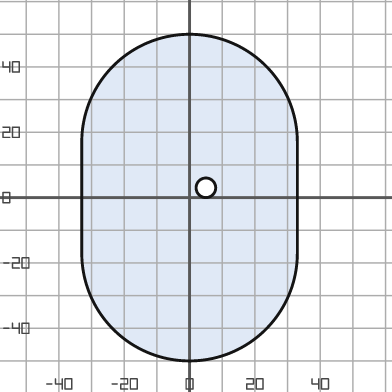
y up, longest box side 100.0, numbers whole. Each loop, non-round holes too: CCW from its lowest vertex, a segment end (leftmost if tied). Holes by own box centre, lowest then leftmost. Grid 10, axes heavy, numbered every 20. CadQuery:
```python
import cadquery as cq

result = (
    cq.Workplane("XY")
    .moveTo(-33.0, -17.0)
    .threePointArc((0.0, -50.0), (33.0, -17.0))
    .lineTo(33.0, 17.0)
    .threePointArc((0.0, 50.0), (-33.0, 17.0))
    .close()
    .moveTo(5.0, 3.0)
    .circle(3.0)
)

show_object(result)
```